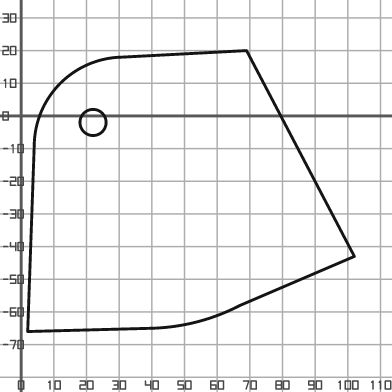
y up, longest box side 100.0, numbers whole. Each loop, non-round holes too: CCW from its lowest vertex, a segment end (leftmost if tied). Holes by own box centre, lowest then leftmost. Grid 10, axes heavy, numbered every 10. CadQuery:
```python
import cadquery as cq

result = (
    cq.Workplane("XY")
    .moveTo(2.0, -66.0)
    .lineTo(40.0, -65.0)
    .threePointArc((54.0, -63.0), (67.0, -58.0))
    .lineTo(102.0, -43.0)
    .lineTo(69.0, 20.0)
    .lineTo(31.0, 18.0)
    .threePointArc((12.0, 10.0), (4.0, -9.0))
    .close()
    .moveTo(22.0, -2.0)
    .circle(4.0)
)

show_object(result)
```